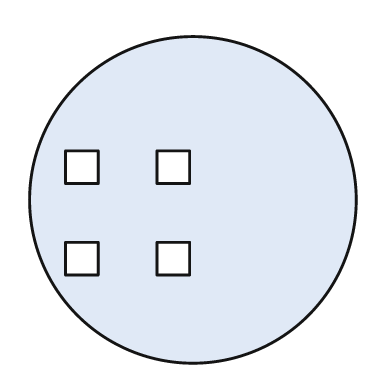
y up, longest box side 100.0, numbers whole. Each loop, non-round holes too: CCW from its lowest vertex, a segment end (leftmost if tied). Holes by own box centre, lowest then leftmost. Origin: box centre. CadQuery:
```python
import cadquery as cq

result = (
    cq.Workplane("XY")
    .moveTo(0.0, 0.0)
    .circle(50.0)
    .moveTo(-39.0, -23.0)
    .lineTo(-29.0, -23.0)
    .lineTo(-29.0, -13.0)
    .lineTo(-39.0, -13.0)
    .close()
    .moveTo(-11.0, -23.0)
    .lineTo(-1.0, -23.0)
    .lineTo(-1.0, -13.0)
    .lineTo(-11.0, -13.0)
    .close()
    .moveTo(-39.0, 5.0)
    .lineTo(-29.0, 5.0)
    .lineTo(-29.0, 15.0)
    .lineTo(-39.0, 15.0)
    .close()
    .moveTo(-11.0, 5.0)
    .lineTo(-1.0, 5.0)
    .lineTo(-1.0, 15.0)
    .lineTo(-11.0, 15.0)
    .close()
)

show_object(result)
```